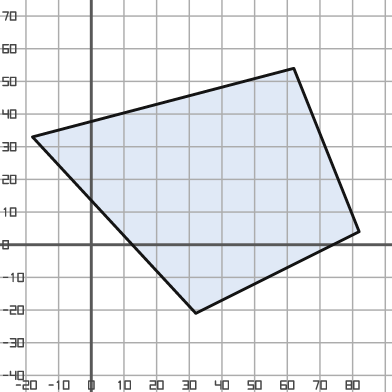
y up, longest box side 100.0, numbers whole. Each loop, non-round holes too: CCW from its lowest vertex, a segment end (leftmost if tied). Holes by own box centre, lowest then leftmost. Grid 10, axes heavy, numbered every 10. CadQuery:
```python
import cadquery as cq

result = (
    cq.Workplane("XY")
    .moveTo(32.0, -21.0)
    .lineTo(82.0, 4.0)
    .lineTo(62.0, 54.0)
    .lineTo(-18.0, 33.0)
    .close()
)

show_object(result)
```